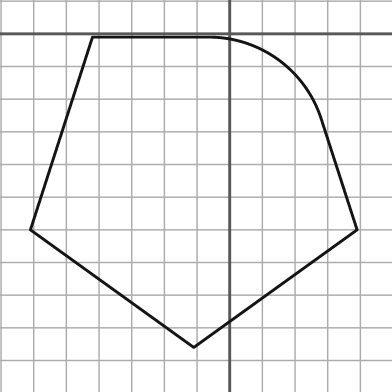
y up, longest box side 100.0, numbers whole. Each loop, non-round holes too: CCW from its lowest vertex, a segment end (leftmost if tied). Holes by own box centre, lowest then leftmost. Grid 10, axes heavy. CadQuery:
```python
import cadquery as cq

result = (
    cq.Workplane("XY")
    .moveTo(-11.0, -96.0)
    .lineTo(39.0, -60.0)
    .lineTo(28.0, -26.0)
    .threePointArc((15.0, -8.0), (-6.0, -1.0))
    .lineTo(-42.0, -1.0)
    .lineTo(-61.0, -60.0)
    .close()
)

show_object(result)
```